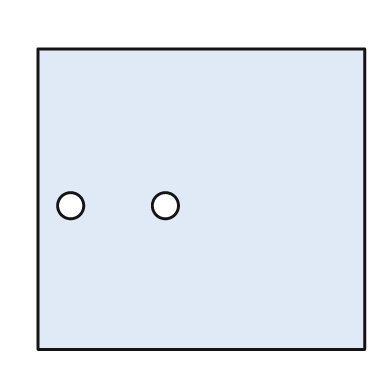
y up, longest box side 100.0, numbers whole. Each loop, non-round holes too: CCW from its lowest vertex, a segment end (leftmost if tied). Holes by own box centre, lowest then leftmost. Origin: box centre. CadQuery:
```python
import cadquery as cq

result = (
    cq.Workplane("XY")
    .moveTo(-50.0, -46.0)
    .lineTo(50.0, -46.0)
    .lineTo(50.0, 46.0)
    .lineTo(-50.0, 46.0)
    .close()
    .moveTo(-40.0, -2.0)
    .circle(4.0)
    .moveTo(-11.0, -2.0)
    .circle(4.0)
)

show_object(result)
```